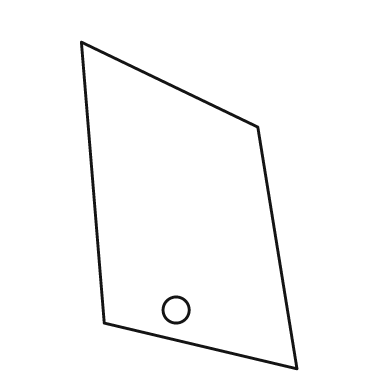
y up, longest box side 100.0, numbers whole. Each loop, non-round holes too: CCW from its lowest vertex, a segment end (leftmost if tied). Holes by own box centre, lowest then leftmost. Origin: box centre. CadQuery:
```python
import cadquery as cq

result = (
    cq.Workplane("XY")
    .moveTo(33.0, -50.0)
    .lineTo(21.0, 24.0)
    .lineTo(-33.0, 50.0)
    .lineTo(-26.0, -36.0)
    .close()
    .moveTo(-4.0, -32.0)
    .circle(4.0)
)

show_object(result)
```